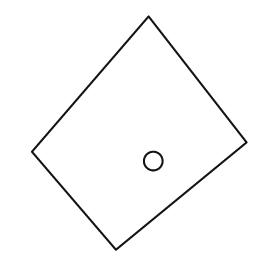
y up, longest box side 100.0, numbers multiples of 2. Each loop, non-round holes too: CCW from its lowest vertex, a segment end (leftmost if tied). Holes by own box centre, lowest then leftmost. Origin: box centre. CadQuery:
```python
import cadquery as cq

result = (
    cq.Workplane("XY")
    .moveTo(-10.0, -50.0)
    .lineTo(46.0, -4.0)
    .lineTo(4.0, 50.0)
    .lineTo(-46.0, -8.0)
    .close()
    .moveTo(6.0, -12.0)
    .circle(4.0)
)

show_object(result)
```